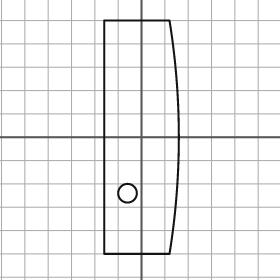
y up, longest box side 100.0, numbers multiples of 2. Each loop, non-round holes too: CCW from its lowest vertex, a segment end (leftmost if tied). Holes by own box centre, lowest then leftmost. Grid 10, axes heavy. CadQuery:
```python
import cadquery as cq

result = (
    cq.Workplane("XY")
    .moveTo(-16.0, -50.0)
    .lineTo(12.0, -50.0)
    .threePointArc((16.0, 0.0), (12.0, 50.0))
    .lineTo(-16.0, 50.0)
    .close()
    .moveTo(-6.0, -24.0)
    .circle(4.0)
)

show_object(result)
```